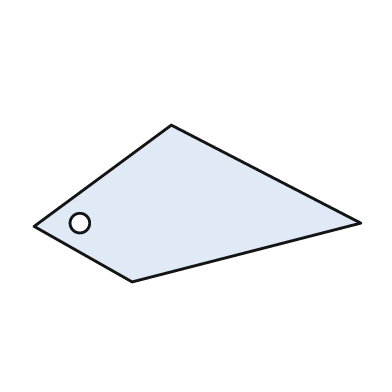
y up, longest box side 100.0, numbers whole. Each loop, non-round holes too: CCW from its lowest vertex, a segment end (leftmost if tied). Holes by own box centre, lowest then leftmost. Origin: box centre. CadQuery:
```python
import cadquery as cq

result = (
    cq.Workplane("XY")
    .moveTo(-20.0, -24.0)
    .lineTo(50.0, -6.0)
    .lineTo(-8.0, 24.0)
    .lineTo(-50.0, -7.0)
    .close()
    .moveTo(-36.0, -6.0)
    .circle(3.0)
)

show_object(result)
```